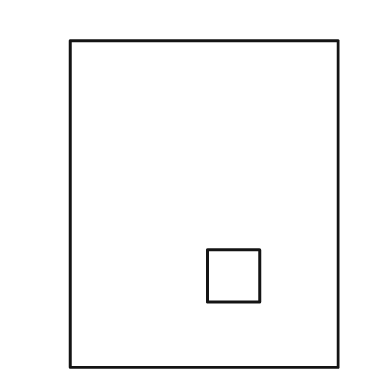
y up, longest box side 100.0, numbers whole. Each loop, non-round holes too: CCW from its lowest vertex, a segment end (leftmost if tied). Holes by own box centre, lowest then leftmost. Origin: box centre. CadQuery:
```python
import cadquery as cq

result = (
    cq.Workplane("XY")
    .moveTo(-41.0, -50.0)
    .lineTo(41.0, -50.0)
    .lineTo(41.0, 50.0)
    .lineTo(-41.0, 50.0)
    .close()
    .moveTo(1.0, -30.0)
    .lineTo(17.0, -30.0)
    .lineTo(17.0, -14.0)
    .lineTo(1.0, -14.0)
    .close()
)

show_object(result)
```